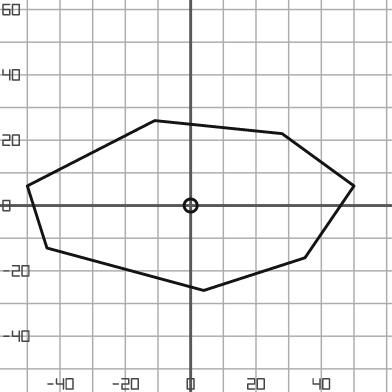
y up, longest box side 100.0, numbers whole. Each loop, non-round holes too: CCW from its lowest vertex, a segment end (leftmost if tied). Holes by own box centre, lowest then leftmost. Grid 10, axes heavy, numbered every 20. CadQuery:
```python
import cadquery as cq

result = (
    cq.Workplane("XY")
    .moveTo(4.0, -26.0)
    .lineTo(35.0, -16.0)
    .lineTo(50.0, 6.0)
    .lineTo(28.0, 22.0)
    .lineTo(-11.0, 26.0)
    .lineTo(-50.0, 6.0)
    .lineTo(-44.0, -13.0)
    .close()
    .moveTo(0.0, 0.0)
    .circle(2.0)
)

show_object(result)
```